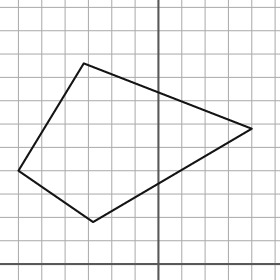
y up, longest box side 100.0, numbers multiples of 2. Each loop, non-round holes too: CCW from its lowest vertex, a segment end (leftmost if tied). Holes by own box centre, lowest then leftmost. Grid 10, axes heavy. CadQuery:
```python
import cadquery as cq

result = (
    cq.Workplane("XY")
    .moveTo(-28.0, 18.0)
    .lineTo(40.0, 58.0)
    .lineTo(-32.0, 86.0)
    .lineTo(-60.0, 40.0)
    .close()
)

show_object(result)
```